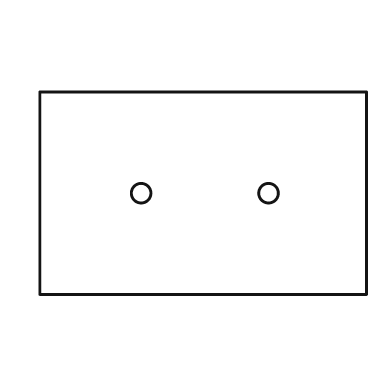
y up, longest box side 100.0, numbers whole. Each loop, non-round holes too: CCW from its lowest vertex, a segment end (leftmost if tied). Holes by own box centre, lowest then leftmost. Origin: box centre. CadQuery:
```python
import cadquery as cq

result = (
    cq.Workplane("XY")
    .moveTo(-50.0, -31.0)
    .lineTo(50.0, -31.0)
    .lineTo(50.0, 31.0)
    .lineTo(-50.0, 31.0)
    .close()
    .moveTo(-19.0, 0.0)
    .circle(3.0)
    .moveTo(20.0, 0.0)
    .circle(3.0)
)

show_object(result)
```